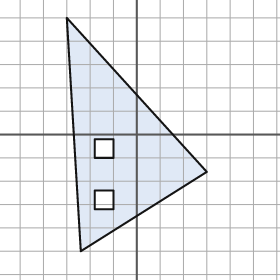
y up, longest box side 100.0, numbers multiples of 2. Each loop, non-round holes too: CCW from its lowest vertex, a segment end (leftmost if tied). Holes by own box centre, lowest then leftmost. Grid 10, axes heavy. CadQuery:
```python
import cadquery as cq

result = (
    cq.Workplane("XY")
    .moveTo(-24.0, -50.0)
    .lineTo(30.0, -16.0)
    .lineTo(-30.0, 50.0)
    .close()
    .moveTo(-18.0, -32.0)
    .lineTo(-10.0, -32.0)
    .lineTo(-10.0, -24.0)
    .lineTo(-18.0, -24.0)
    .close()
    .moveTo(-18.0, -10.0)
    .lineTo(-10.0, -10.0)
    .lineTo(-10.0, -2.0)
    .lineTo(-18.0, -2.0)
    .close()
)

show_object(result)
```